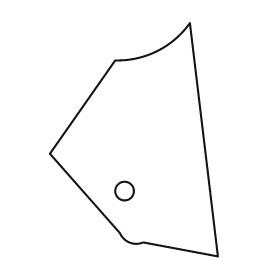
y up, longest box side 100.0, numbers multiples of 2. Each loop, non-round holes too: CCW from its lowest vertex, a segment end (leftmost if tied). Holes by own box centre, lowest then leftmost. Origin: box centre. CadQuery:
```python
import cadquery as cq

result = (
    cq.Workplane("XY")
    .moveTo(36.0, -50.0)
    .lineTo(24.0, 50.0)
    .threePointArc((10.0, 38.0), (-8.0, 34.0))
    .lineTo(-36.0, -6.0)
    .lineTo(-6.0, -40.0)
    .threePointArc((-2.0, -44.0), (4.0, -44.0))
    .close()
    .moveTo(-4.0, -22.0)
    .circle(4.0)
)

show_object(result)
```